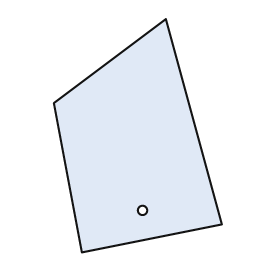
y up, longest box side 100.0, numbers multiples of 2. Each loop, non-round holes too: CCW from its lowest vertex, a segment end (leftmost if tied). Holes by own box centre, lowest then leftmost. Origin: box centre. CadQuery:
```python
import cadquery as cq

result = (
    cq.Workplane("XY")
    .moveTo(-24.0, -50.0)
    .lineTo(36.0, -38.0)
    .lineTo(12.0, 50.0)
    .lineTo(-36.0, 14.0)
    .close()
    .moveTo(2.0, -32.0)
    .circle(2.0)
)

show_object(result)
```